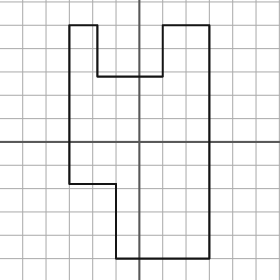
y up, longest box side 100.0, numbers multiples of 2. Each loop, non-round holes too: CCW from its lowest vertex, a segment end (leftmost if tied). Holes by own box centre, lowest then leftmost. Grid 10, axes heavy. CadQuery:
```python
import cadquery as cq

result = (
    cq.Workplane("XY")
    .moveTo(-10.0, -50.0)
    .lineTo(30.0, -50.0)
    .lineTo(30.0, 50.0)
    .lineTo(10.0, 50.0)
    .lineTo(10.0, 28.0)
    .lineTo(-18.0, 28.0)
    .lineTo(-18.0, 50.0)
    .lineTo(-30.0, 50.0)
    .lineTo(-30.0, -18.0)
    .lineTo(-10.0, -18.0)
    .close()
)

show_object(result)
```